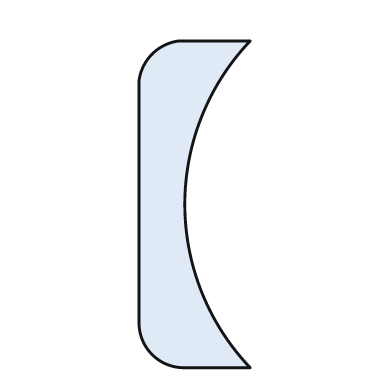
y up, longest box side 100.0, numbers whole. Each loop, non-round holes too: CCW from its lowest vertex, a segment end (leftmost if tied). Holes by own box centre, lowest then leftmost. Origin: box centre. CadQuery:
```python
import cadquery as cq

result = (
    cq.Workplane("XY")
    .moveTo(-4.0, -50.0)
    .lineTo(17.0, -50.0)
    .threePointArc((-3.0, 0.0), (17.0, 50.0))
    .lineTo(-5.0, 50.0)
    .threePointArc((-13.0, 46.0), (-17.0, 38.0))
    .lineTo(-17.0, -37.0)
    .threePointArc((-13.0, -46.0), (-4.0, -50.0))
    .close()
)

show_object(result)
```